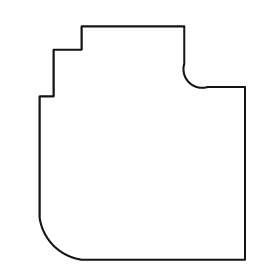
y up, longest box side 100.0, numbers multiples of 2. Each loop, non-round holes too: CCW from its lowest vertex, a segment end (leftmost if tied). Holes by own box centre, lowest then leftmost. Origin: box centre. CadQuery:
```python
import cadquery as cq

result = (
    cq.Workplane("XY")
    .moveTo(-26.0, -50.0)
    .lineTo(44.0, -50.0)
    .lineTo(44.0, 24.0)
    .lineTo(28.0, 24.0)
    .threePointArc((20.0, 26.0), (18.0, 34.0))
    .lineTo(18.0, 50.0)
    .lineTo(-26.0, 50.0)
    .lineTo(-26.0, 40.0)
    .lineTo(-38.0, 40.0)
    .lineTo(-38.0, 20.0)
    .lineTo(-44.0, 20.0)
    .lineTo(-44.0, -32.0)
    .threePointArc((-38.0, -44.0), (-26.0, -50.0))
    .close()
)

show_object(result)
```